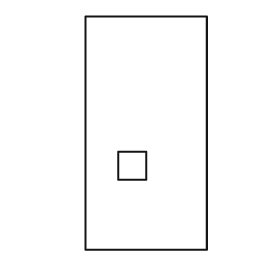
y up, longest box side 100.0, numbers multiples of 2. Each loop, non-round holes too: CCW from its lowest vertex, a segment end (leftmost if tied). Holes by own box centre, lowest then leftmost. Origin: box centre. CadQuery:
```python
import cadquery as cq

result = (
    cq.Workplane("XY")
    .moveTo(-26.0, -50.0)
    .lineTo(26.0, -50.0)
    .lineTo(26.0, 50.0)
    .lineTo(-26.0, 50.0)
    .close()
    .moveTo(-12.0, -20.0)
    .lineTo(0.0, -20.0)
    .lineTo(0.0, -8.0)
    .lineTo(-12.0, -8.0)
    .close()
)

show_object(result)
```